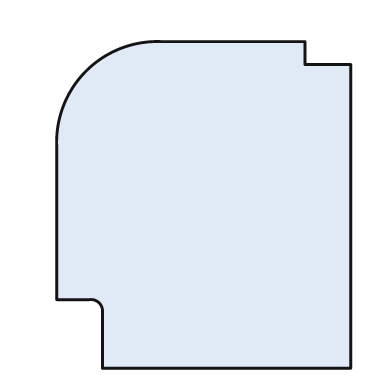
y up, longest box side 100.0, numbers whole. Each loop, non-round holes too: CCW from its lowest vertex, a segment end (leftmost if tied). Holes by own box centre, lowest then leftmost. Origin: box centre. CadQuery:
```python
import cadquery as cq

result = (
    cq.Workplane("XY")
    .moveTo(-31.0, -50.0)
    .lineTo(45.0, -50.0)
    .lineTo(45.0, 43.0)
    .lineTo(31.0, 43.0)
    .lineTo(31.0, 50.0)
    .lineTo(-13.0, 50.0)
    .threePointArc((-36.0, 41.0), (-45.0, 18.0))
    .lineTo(-45.0, -29.0)
    .lineTo(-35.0, -29.0)
    .threePointArc((-32.0, -30.0), (-31.0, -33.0))
    .close()
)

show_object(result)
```